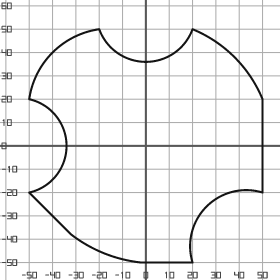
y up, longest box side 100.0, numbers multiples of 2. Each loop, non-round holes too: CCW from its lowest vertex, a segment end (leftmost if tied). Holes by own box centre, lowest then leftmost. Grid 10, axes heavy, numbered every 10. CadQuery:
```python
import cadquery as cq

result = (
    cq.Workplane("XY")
    .moveTo(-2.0, -50.0)
    .lineTo(20.0, -50.0)
    .threePointArc((26.0, -26.0), (50.0, -20.0))
    .lineTo(50.0, 20.0)
    .threePointArc((38.0, 38.0), (20.0, 50.0))
    .threePointArc((0.0, 36.0), (-20.0, 50.0))
    .threePointArc((-40.0, 40.0), (-50.0, 20.0))
    .threePointArc((-34.0, 0.0), (-50.0, -20.0))
    .lineTo(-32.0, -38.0)
    .threePointArc((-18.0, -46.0), (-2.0, -50.0))
    .close()
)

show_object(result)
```